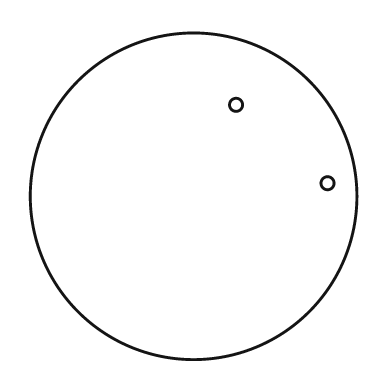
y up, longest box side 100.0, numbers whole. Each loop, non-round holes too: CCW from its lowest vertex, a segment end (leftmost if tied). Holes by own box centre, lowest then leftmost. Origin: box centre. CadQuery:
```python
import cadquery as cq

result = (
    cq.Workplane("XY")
    .moveTo(0.0, 0.0)
    .circle(50.0)
    .moveTo(41.0, 4.0)
    .circle(2.0)
    .moveTo(13.0, 28.0)
    .circle(2.0)
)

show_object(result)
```